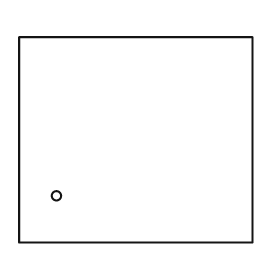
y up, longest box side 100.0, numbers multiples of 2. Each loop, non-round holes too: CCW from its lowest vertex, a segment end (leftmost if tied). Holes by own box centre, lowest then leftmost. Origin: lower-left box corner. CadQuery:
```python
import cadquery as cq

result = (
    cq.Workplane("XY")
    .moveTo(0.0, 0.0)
    .lineTo(100.0, 0.0)
    .lineTo(100.0, 88.0)
    .lineTo(0.0, 88.0)
    .close()
    .moveTo(16.0, 20.0)
    .circle(2.0)
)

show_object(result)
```